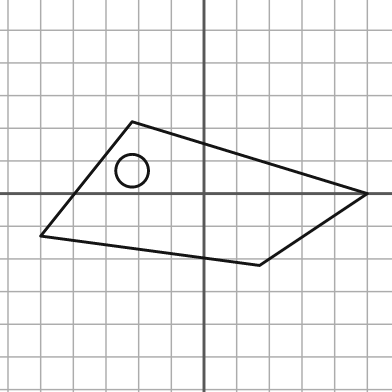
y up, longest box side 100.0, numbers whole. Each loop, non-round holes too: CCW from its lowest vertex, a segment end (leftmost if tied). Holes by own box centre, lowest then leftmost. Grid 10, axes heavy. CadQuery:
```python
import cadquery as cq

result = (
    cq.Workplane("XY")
    .moveTo(17.0, -22.0)
    .lineTo(50.0, 0.0)
    .lineTo(-22.0, 22.0)
    .lineTo(-50.0, -13.0)
    .close()
    .moveTo(-22.0, 7.0)
    .circle(5.0)
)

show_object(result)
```